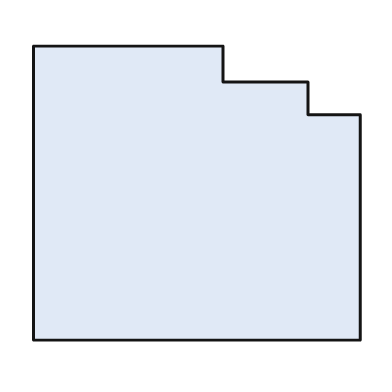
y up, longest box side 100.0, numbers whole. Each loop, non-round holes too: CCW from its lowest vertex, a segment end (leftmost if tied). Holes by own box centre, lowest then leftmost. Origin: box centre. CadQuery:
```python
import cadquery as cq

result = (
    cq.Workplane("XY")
    .moveTo(-50.0, -45.0)
    .lineTo(50.0, -45.0)
    .lineTo(50.0, 24.0)
    .lineTo(34.0, 24.0)
    .lineTo(34.0, 34.0)
    .lineTo(8.0, 34.0)
    .lineTo(8.0, 45.0)
    .lineTo(-50.0, 45.0)
    .close()
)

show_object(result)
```